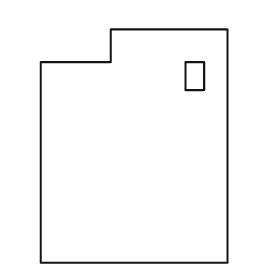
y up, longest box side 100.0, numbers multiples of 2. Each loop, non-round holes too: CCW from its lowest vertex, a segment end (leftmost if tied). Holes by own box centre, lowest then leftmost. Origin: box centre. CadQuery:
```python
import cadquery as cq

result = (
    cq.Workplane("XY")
    .moveTo(-40.0, -50.0)
    .lineTo(40.0, -50.0)
    .lineTo(40.0, 50.0)
    .lineTo(-10.0, 50.0)
    .lineTo(-10.0, 36.0)
    .lineTo(-40.0, 36.0)
    .close()
    .moveTo(22.0, 24.0)
    .lineTo(30.0, 24.0)
    .lineTo(30.0, 36.0)
    .lineTo(22.0, 36.0)
    .close()
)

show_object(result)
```